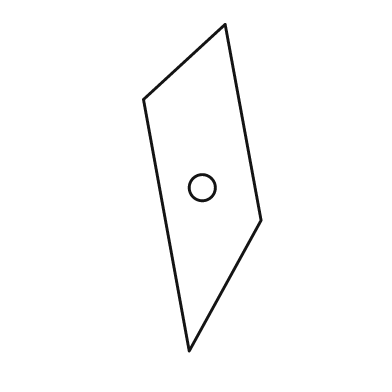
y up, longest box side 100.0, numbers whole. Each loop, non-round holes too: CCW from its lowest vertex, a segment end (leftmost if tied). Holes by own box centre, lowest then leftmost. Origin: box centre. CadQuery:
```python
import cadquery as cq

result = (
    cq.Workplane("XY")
    .moveTo(-4.0, -50.0)
    .lineTo(18.0, -10.0)
    .lineTo(7.0, 50.0)
    .lineTo(-18.0, 27.0)
    .close()
    .moveTo(0.0, 0.0)
    .circle(4.0)
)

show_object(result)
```